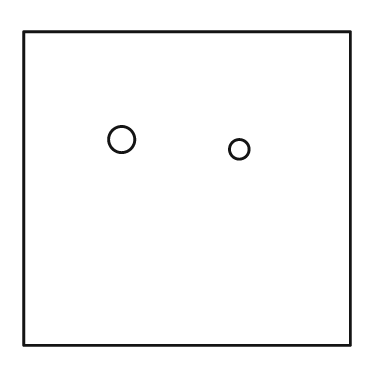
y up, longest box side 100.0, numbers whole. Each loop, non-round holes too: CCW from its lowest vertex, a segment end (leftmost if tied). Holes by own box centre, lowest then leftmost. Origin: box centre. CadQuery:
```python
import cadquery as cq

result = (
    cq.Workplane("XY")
    .moveTo(-50.0, -48.0)
    .lineTo(50.0, -48.0)
    .lineTo(50.0, 48.0)
    .lineTo(-50.0, 48.0)
    .close()
    .moveTo(16.0, 12.0)
    .circle(3.0)
    .moveTo(-20.0, 15.0)
    .circle(4.0)
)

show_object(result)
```